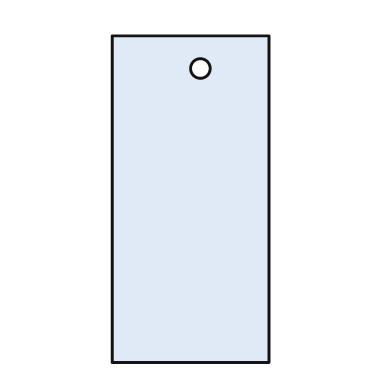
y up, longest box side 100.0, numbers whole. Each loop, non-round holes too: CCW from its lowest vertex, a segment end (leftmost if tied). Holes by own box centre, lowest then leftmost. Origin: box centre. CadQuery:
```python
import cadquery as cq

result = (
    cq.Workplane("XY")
    .moveTo(-24.0, -50.0)
    .lineTo(24.0, -50.0)
    .lineTo(24.0, 50.0)
    .lineTo(-24.0, 50.0)
    .close()
    .moveTo(3.0, 40.0)
    .circle(3.0)
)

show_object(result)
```